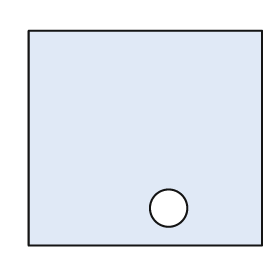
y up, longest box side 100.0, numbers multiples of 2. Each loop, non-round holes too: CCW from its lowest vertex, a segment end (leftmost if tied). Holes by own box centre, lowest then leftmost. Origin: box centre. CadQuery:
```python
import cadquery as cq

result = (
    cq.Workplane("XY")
    .moveTo(-50.0, -46.0)
    .lineTo(50.0, -46.0)
    .lineTo(50.0, 46.0)
    .lineTo(-50.0, 46.0)
    .close()
    .moveTo(10.0, -30.0)
    .circle(8.0)
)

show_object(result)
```